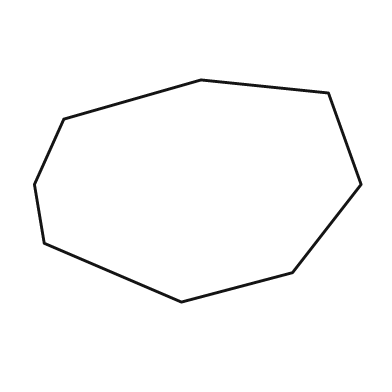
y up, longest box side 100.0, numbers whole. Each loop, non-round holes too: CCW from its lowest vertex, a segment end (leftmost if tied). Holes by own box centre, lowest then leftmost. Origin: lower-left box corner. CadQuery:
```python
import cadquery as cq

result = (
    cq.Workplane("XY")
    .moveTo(45.0, 0.0)
    .lineTo(79.0, 9.0)
    .lineTo(100.0, 36.0)
    .lineTo(90.0, 64.0)
    .lineTo(51.0, 68.0)
    .lineTo(9.0, 56.0)
    .lineTo(0.0, 36.0)
    .lineTo(3.0, 18.0)
    .close()
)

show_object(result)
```